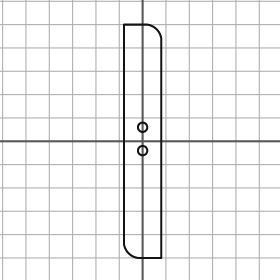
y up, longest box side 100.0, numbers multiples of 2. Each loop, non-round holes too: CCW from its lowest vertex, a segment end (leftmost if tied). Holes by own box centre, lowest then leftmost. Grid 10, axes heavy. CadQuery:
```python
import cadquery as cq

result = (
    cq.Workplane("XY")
    .moveTo(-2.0, -50.0)
    .lineTo(8.0, -50.0)
    .lineTo(8.0, 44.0)
    .threePointArc((6.0, 48.0), (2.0, 50.0))
    .lineTo(-8.0, 50.0)
    .lineTo(-8.0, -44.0)
    .threePointArc((-6.0, -48.0), (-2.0, -50.0))
    .close()
    .moveTo(0.0, -4.0)
    .circle(2.0)
    .moveTo(0.0, 6.0)
    .circle(2.0)
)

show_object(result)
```